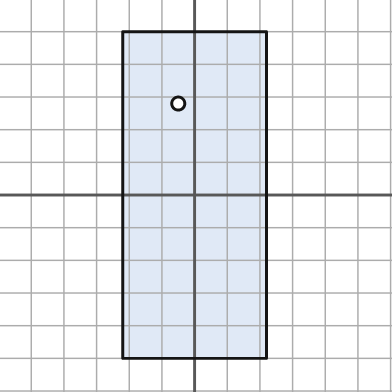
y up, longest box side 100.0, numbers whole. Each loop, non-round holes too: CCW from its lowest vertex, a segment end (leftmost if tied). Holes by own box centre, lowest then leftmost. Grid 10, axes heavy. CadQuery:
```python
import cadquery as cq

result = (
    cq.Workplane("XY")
    .moveTo(-22.0, -50.0)
    .lineTo(22.0, -50.0)
    .lineTo(22.0, 50.0)
    .lineTo(-22.0, 50.0)
    .close()
    .moveTo(-5.0, 28.0)
    .circle(2.0)
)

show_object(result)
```